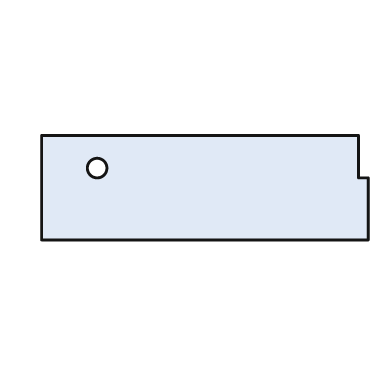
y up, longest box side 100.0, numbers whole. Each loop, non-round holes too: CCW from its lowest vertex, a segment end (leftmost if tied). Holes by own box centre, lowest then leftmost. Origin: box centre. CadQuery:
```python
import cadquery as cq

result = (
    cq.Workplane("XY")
    .moveTo(-50.0, -16.0)
    .lineTo(50.0, -16.0)
    .lineTo(50.0, 3.0)
    .lineTo(47.0, 3.0)
    .lineTo(47.0, 16.0)
    .lineTo(-50.0, 16.0)
    .close()
    .moveTo(-33.0, 6.0)
    .circle(3.0)
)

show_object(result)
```